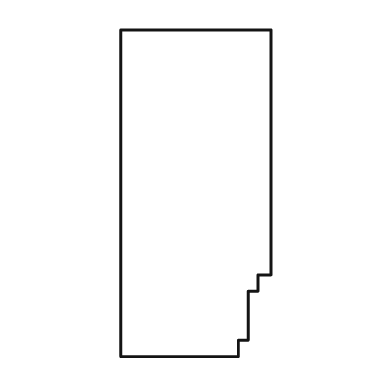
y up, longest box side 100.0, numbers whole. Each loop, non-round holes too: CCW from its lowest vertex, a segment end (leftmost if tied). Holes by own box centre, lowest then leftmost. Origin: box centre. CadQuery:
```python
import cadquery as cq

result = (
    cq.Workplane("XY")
    .moveTo(-23.0, -50.0)
    .lineTo(13.0, -50.0)
    .lineTo(13.0, -45.0)
    .lineTo(16.0, -45.0)
    .lineTo(16.0, -30.0)
    .lineTo(19.0, -30.0)
    .lineTo(19.0, -25.0)
    .lineTo(23.0, -25.0)
    .lineTo(23.0, 50.0)
    .lineTo(-23.0, 50.0)
    .close()
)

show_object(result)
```